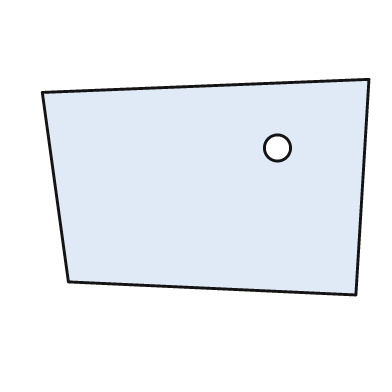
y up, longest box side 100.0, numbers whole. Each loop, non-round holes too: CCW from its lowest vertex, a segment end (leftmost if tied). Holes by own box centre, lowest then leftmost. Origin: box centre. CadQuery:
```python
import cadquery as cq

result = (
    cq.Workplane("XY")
    .moveTo(46.0, -33.0)
    .lineTo(50.0, 33.0)
    .lineTo(-50.0, 29.0)
    .lineTo(-42.0, -29.0)
    .close()
    .moveTo(22.0, 12.0)
    .circle(4.0)
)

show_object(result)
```